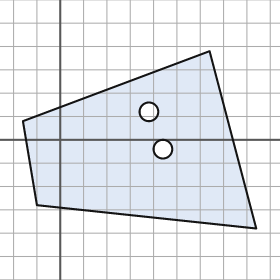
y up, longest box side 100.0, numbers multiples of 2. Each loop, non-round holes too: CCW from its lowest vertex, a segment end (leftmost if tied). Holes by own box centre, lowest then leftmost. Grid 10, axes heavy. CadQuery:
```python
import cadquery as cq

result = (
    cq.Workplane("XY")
    .moveTo(84.0, -38.0)
    .lineTo(64.0, 38.0)
    .lineTo(-16.0, 8.0)
    .lineTo(-10.0, -28.0)
    .close()
    .moveTo(44.0, -4.0)
    .circle(4.0)
    .moveTo(38.0, 12.0)
    .circle(4.0)
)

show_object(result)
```